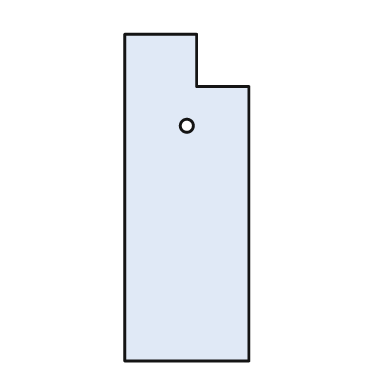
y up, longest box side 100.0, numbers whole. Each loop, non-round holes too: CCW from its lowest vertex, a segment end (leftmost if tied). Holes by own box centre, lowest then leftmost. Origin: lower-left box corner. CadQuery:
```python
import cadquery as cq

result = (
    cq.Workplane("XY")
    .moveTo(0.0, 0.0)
    .lineTo(38.0, 0.0)
    .lineTo(38.0, 84.0)
    .lineTo(22.0, 84.0)
    .lineTo(22.0, 100.0)
    .lineTo(0.0, 100.0)
    .close()
    .moveTo(19.0, 72.0)
    .circle(2.0)
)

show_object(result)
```